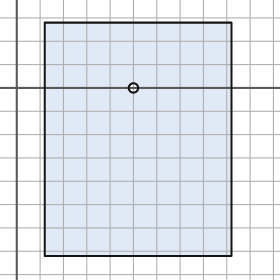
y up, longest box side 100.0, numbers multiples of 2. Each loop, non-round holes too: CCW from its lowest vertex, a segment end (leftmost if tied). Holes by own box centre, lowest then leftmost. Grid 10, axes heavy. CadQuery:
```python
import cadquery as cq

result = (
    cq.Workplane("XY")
    .moveTo(12.0, -72.0)
    .lineTo(92.0, -72.0)
    .lineTo(92.0, 28.0)
    .lineTo(12.0, 28.0)
    .close()
    .moveTo(50.0, 0.0)
    .circle(2.0)
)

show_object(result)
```